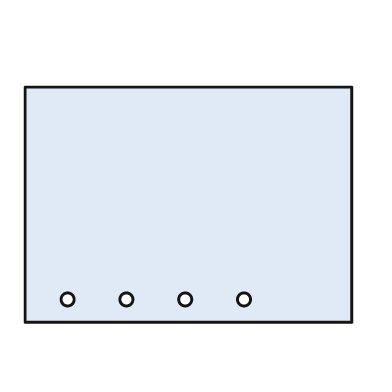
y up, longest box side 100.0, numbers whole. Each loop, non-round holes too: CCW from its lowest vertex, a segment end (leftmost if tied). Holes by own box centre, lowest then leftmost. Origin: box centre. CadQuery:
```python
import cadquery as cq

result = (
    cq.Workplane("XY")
    .moveTo(-50.0, -36.0)
    .lineTo(50.0, -36.0)
    .lineTo(50.0, 36.0)
    .lineTo(-50.0, 36.0)
    .close()
    .moveTo(-37.0, -29.0)
    .circle(2.0)
    .moveTo(-19.0, -29.0)
    .circle(2.0)
    .moveTo(-1.0, -29.0)
    .circle(2.0)
    .moveTo(17.0, -29.0)
    .circle(2.0)
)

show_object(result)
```